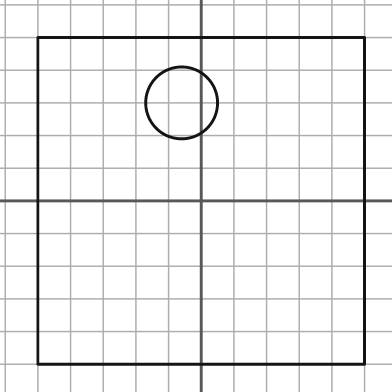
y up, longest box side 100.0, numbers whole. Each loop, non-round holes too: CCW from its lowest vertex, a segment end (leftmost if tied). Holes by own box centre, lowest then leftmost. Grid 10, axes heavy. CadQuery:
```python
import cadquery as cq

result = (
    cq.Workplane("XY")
    .moveTo(-50.0, -50.0)
    .lineTo(50.0, -50.0)
    .lineTo(50.0, 50.0)
    .lineTo(-50.0, 50.0)
    .close()
    .moveTo(-6.0, 30.0)
    .circle(11.0)
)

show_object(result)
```